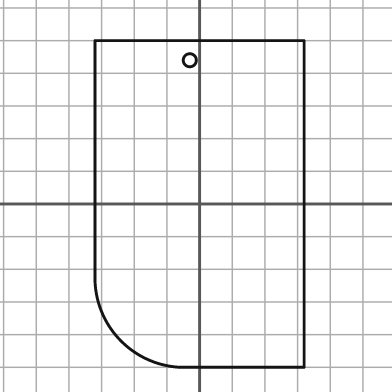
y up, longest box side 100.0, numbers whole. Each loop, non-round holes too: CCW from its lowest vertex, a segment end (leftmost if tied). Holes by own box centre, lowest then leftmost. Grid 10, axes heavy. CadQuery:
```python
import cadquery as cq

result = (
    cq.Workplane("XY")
    .moveTo(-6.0, -50.0)
    .lineTo(32.0, -50.0)
    .lineTo(32.0, 50.0)
    .lineTo(-32.0, 50.0)
    .lineTo(-32.0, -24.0)
    .threePointArc((-24.0, -42.0), (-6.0, -50.0))
    .close()
    .moveTo(-3.0, 44.0)
    .circle(2.0)
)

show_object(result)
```